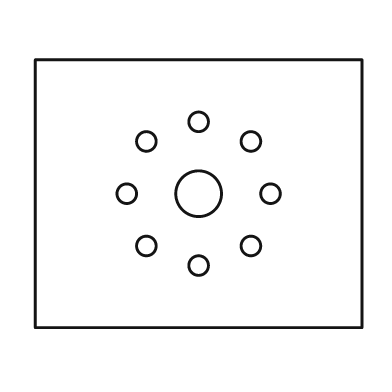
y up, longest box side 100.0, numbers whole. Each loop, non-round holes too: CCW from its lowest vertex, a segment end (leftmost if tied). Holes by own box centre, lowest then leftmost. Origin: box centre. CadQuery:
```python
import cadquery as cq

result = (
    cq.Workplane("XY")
    .moveTo(-50.0, -41.0)
    .lineTo(50.0, -41.0)
    .lineTo(50.0, 41.0)
    .lineTo(-50.0, 41.0)
    .close()
    .moveTo(0.0, -22.0)
    .circle(3.0)
    .moveTo(-16.0, -16.0)
    .circle(3.0)
    .moveTo(16.0, -16.0)
    .circle(3.0)
    .moveTo(-22.0, 0.0)
    .circle(3.0)
    .moveTo(0.0, 0.0)
    .circle(7.0)
    .moveTo(22.0, 0.0)
    .circle(3.0)
    .moveTo(-16.0, 16.0)
    .circle(3.0)
    .moveTo(16.0, 16.0)
    .circle(3.0)
    .moveTo(0.0, 22.0)
    .circle(3.0)
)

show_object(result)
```